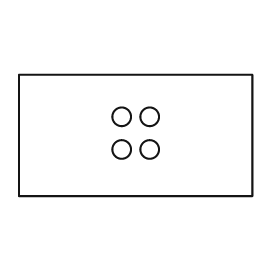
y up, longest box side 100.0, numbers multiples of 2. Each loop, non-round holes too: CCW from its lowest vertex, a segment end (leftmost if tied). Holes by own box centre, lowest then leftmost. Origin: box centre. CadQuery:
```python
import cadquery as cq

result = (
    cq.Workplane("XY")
    .moveTo(-50.0, -26.0)
    .lineTo(50.0, -26.0)
    .lineTo(50.0, 26.0)
    .lineTo(-50.0, 26.0)
    .close()
    .moveTo(-6.0, -6.0)
    .circle(4.0)
    .moveTo(6.0, -6.0)
    .circle(4.0)
    .moveTo(-6.0, 8.0)
    .circle(4.0)
    .moveTo(6.0, 8.0)
    .circle(4.0)
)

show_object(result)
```